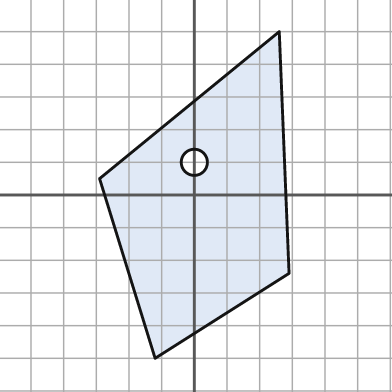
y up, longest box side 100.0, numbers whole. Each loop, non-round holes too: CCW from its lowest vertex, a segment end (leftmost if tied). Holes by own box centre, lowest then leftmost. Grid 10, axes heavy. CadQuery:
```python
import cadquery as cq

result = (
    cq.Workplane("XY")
    .moveTo(-12.0, -50.0)
    .lineTo(29.0, -24.0)
    .lineTo(26.0, 50.0)
    .lineTo(-29.0, 5.0)
    .close()
    .moveTo(0.0, 10.0)
    .circle(4.0)
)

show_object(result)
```